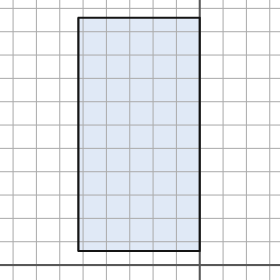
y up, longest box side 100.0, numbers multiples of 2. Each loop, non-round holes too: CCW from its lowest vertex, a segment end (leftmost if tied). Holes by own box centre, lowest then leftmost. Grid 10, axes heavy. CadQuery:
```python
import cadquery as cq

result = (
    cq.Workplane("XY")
    .moveTo(-52.0, 6.0)
    .lineTo(0.0, 6.0)
    .lineTo(0.0, 106.0)
    .lineTo(-52.0, 106.0)
    .close()
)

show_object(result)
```